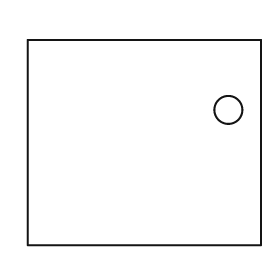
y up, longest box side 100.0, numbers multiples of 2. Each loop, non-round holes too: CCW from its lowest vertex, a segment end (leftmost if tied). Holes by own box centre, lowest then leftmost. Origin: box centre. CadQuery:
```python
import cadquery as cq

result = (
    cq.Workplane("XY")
    .moveTo(-50.0, -44.0)
    .lineTo(50.0, -44.0)
    .lineTo(50.0, 44.0)
    .lineTo(-50.0, 44.0)
    .close()
    .moveTo(36.0, 14.0)
    .circle(6.0)
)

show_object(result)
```